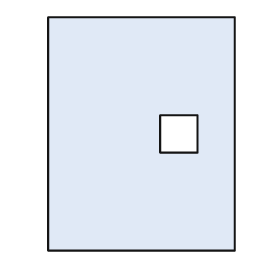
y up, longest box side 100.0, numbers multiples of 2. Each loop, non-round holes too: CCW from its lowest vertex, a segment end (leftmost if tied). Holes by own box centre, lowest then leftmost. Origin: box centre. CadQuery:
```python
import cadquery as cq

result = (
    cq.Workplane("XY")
    .moveTo(-40.0, -50.0)
    .lineTo(40.0, -50.0)
    .lineTo(40.0, 50.0)
    .lineTo(-40.0, 50.0)
    .close()
    .moveTo(8.0, -8.0)
    .lineTo(24.0, -8.0)
    .lineTo(24.0, 8.0)
    .lineTo(8.0, 8.0)
    .close()
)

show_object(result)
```